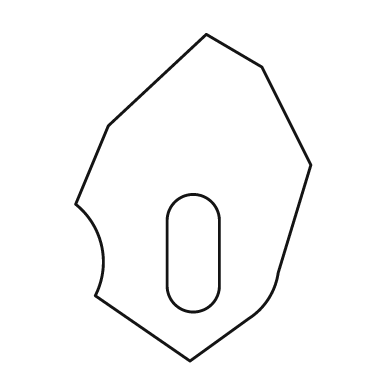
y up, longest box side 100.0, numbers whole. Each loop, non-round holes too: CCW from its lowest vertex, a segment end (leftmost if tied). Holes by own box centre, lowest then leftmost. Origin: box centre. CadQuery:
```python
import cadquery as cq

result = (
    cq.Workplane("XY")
    .moveTo(-1.0, -50.0)
    .lineTo(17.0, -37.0)
    .threePointArc((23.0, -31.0), (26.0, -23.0))
    .lineTo(36.0, 10.0)
    .lineTo(21.0, 40.0)
    .lineTo(4.0, 50.0)
    .lineTo(-26.0, 22.0)
    .lineTo(-36.0, -2.0)
    .threePointArc((-28.0, -15.0), (-30.0, -30.0))
    .close()
    .moveTo(-8.0, -27.0)
    .threePointArc((0.0, -35.0), (8.0, -27.0))
    .lineTo(8.0, -7.0)
    .threePointArc((0.0, 1.0), (-8.0, -7.0))
    .close()
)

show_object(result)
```